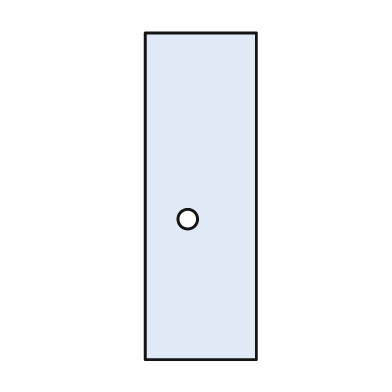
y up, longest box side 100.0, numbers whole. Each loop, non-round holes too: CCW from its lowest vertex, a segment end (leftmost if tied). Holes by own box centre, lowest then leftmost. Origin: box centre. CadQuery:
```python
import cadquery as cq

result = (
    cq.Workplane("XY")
    .moveTo(-17.0, -50.0)
    .lineTo(17.0, -50.0)
    .lineTo(17.0, 50.0)
    .lineTo(-17.0, 50.0)
    .close()
    .moveTo(-4.0, -7.0)
    .circle(3.0)
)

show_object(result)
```